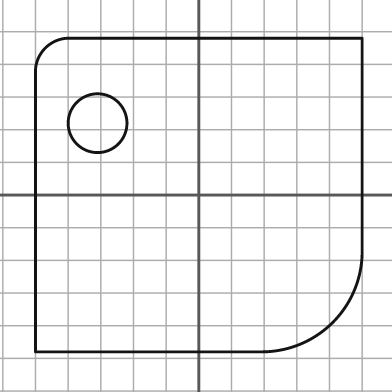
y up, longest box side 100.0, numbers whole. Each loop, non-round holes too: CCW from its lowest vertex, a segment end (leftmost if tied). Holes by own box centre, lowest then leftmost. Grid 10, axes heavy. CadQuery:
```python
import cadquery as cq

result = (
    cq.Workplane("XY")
    .moveTo(-50.0, -48.0)
    .lineTo(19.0, -48.0)
    .threePointArc((41.0, -39.0), (50.0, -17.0))
    .lineTo(50.0, 48.0)
    .lineTo(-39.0, 48.0)
    .threePointArc((-47.0, 45.0), (-50.0, 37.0))
    .close()
    .moveTo(-31.0, 22.0)
    .circle(9.0)
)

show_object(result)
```